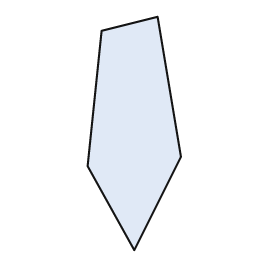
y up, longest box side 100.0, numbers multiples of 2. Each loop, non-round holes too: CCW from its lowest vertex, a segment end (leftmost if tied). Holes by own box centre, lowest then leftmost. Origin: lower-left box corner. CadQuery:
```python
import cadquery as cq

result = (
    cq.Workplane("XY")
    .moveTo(20.0, 0.0)
    .lineTo(40.0, 40.0)
    .lineTo(30.0, 100.0)
    .lineTo(6.0, 94.0)
    .lineTo(0.0, 36.0)
    .close()
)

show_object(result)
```